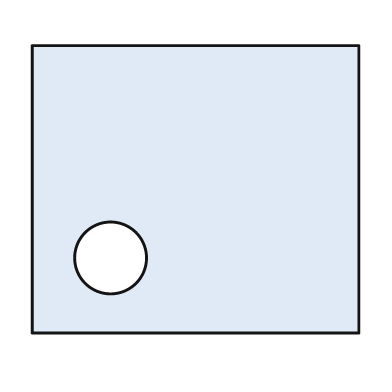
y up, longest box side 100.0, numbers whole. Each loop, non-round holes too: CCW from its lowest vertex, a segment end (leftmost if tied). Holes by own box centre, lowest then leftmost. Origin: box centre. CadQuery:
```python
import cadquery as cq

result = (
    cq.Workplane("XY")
    .moveTo(-50.0, -44.0)
    .lineTo(50.0, -44.0)
    .lineTo(50.0, 44.0)
    .lineTo(-50.0, 44.0)
    .close()
    .moveTo(-26.0, -21.0)
    .circle(11.0)
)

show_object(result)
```